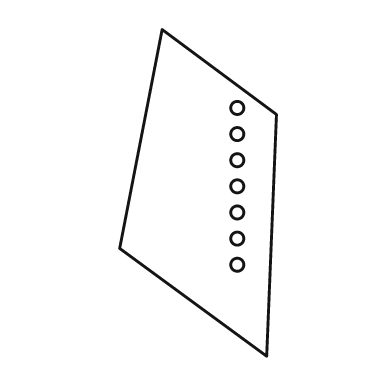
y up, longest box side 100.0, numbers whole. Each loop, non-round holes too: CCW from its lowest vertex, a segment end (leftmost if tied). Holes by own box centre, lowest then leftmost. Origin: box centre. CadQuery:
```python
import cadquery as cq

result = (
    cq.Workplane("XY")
    .moveTo(21.0, -50.0)
    .lineTo(24.0, 24.0)
    .lineTo(-11.0, 50.0)
    .lineTo(-24.0, -17.0)
    .close()
    .moveTo(12.0, -22.0)
    .circle(2.0)
    .moveTo(12.0, -14.0)
    .circle(2.0)
    .moveTo(12.0, -6.0)
    .circle(2.0)
    .moveTo(12.0, 2.0)
    .circle(2.0)
    .moveTo(12.0, 10.0)
    .circle(2.0)
    .moveTo(12.0, 18.0)
    .circle(2.0)
    .moveTo(12.0, 26.0)
    .circle(2.0)
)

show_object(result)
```